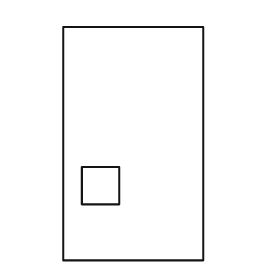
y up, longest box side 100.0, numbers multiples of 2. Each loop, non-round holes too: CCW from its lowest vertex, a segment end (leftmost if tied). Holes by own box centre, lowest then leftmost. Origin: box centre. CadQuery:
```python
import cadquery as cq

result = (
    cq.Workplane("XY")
    .moveTo(-30.0, -50.0)
    .lineTo(30.0, -50.0)
    .lineTo(30.0, 50.0)
    .lineTo(-30.0, 50.0)
    .close()
    .moveTo(-22.0, -26.0)
    .lineTo(-6.0, -26.0)
    .lineTo(-6.0, -10.0)
    .lineTo(-22.0, -10.0)
    .close()
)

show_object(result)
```